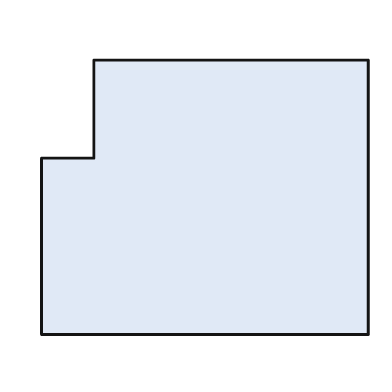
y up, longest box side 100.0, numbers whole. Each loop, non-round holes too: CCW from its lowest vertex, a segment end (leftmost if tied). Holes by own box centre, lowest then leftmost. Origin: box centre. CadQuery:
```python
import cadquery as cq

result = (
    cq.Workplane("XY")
    .moveTo(-50.0, -42.0)
    .lineTo(50.0, -42.0)
    .lineTo(50.0, 42.0)
    .lineTo(-34.0, 42.0)
    .lineTo(-34.0, 12.0)
    .lineTo(-50.0, 12.0)
    .close()
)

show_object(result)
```